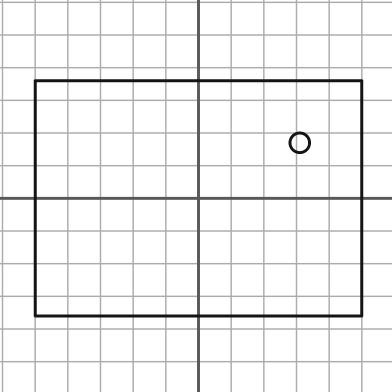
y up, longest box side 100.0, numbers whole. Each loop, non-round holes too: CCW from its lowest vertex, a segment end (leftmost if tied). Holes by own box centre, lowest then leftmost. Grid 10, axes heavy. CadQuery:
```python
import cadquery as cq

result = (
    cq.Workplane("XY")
    .moveTo(-50.0, -36.0)
    .lineTo(50.0, -36.0)
    .lineTo(50.0, 36.0)
    .lineTo(-50.0, 36.0)
    .close()
    .moveTo(31.0, 17.0)
    .circle(3.0)
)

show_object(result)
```